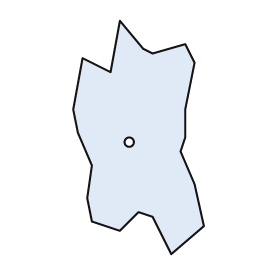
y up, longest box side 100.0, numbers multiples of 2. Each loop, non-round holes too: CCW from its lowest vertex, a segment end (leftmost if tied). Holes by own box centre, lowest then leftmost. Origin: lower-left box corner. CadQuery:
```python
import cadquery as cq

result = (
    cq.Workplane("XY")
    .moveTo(42.0, 0.0)
    .lineTo(56.0, 12.0)
    .lineTo(52.0, 30.0)
    .lineTo(46.0, 44.0)
    .lineTo(48.0, 50.0)
    .lineTo(48.0, 62.0)
    .lineTo(52.0, 82.0)
    .lineTo(48.0, 90.0)
    .lineTo(34.0, 86.0)
    .lineTo(30.0, 88.0)
    .lineTo(20.0, 100.0)
    .lineTo(16.0, 78.0)
    .lineTo(4.0, 84.0)
    .lineTo(0.0, 62.0)
    .lineTo(2.0, 52.0)
    .lineTo(8.0, 38.0)
    .lineTo(6.0, 24.0)
    .lineTo(8.0, 14.0)
    .lineTo(20.0, 10.0)
    .lineTo(28.0, 18.0)
    .lineTo(34.0, 16.0)
    .close()
    .moveTo(24.0, 48.0)
    .circle(2.0)
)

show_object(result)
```